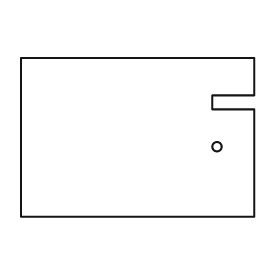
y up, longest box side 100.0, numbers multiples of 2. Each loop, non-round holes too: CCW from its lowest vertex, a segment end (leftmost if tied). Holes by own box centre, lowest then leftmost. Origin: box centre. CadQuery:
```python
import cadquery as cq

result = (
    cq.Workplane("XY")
    .moveTo(-50.0, -34.0)
    .lineTo(50.0, -34.0)
    .lineTo(50.0, 12.0)
    .lineTo(32.0, 12.0)
    .lineTo(32.0, 18.0)
    .lineTo(50.0, 18.0)
    .lineTo(50.0, 34.0)
    .lineTo(-50.0, 34.0)
    .close()
    .moveTo(34.0, -4.0)
    .circle(2.0)
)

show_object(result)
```